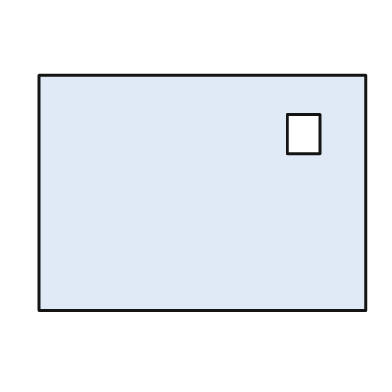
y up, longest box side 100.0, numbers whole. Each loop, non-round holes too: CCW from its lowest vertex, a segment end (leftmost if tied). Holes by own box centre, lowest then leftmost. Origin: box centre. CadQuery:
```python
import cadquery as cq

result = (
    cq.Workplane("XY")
    .moveTo(-50.0, -36.0)
    .lineTo(50.0, -36.0)
    .lineTo(50.0, 36.0)
    .lineTo(-50.0, 36.0)
    .close()
    .moveTo(26.0, 12.0)
    .lineTo(36.0, 12.0)
    .lineTo(36.0, 24.0)
    .lineTo(26.0, 24.0)
    .close()
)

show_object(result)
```